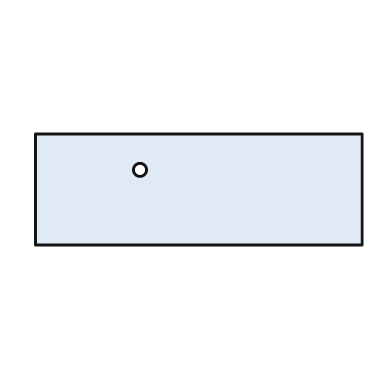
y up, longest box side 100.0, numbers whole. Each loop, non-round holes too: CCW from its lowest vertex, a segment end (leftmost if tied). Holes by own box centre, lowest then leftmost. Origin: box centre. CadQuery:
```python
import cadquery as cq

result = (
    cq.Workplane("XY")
    .moveTo(-50.0, -17.0)
    .lineTo(50.0, -17.0)
    .lineTo(50.0, 17.0)
    .lineTo(-50.0, 17.0)
    .close()
    .moveTo(-18.0, 6.0)
    .circle(2.0)
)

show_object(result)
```